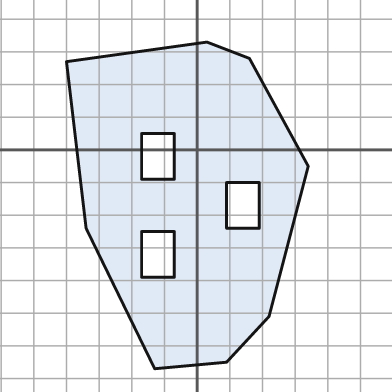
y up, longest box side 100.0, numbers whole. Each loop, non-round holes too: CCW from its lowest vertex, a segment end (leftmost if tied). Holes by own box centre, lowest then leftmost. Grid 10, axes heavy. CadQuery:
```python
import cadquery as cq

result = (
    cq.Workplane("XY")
    .moveTo(-13.0, -67.0)
    .lineTo(9.0, -65.0)
    .lineTo(22.0, -51.0)
    .lineTo(34.0, -5.0)
    .lineTo(16.0, 28.0)
    .lineTo(3.0, 33.0)
    .lineTo(-40.0, 27.0)
    .lineTo(-34.0, -24.0)
    .close()
    .moveTo(-17.0, -39.0)
    .lineTo(-7.0, -39.0)
    .lineTo(-7.0, -25.0)
    .lineTo(-17.0, -25.0)
    .close()
    .moveTo(9.0, -24.0)
    .lineTo(19.0, -24.0)
    .lineTo(19.0, -10.0)
    .lineTo(9.0, -10.0)
    .close()
    .moveTo(-17.0, -9.0)
    .lineTo(-7.0, -9.0)
    .lineTo(-7.0, 5.0)
    .lineTo(-17.0, 5.0)
    .close()
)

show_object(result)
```